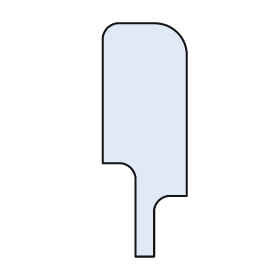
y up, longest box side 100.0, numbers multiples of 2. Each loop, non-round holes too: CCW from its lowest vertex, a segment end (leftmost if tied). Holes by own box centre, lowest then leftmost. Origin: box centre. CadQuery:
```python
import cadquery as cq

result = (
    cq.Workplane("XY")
    .moveTo(-4.0, -50.0)
    .lineTo(4.0, -50.0)
    .lineTo(4.0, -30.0)
    .threePointArc((6.0, -26.0), (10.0, -24.0))
    .lineTo(18.0, -24.0)
    .lineTo(18.0, 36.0)
    .threePointArc((14.0, 46.0), (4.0, 50.0))
    .lineTo(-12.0, 50.0)
    .threePointArc((-16.0, 48.0), (-18.0, 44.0))
    .lineTo(-18.0, -10.0)
    .lineTo(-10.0, -10.0)
    .threePointArc((-6.0, -12.0), (-4.0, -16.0))
    .close()
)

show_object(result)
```